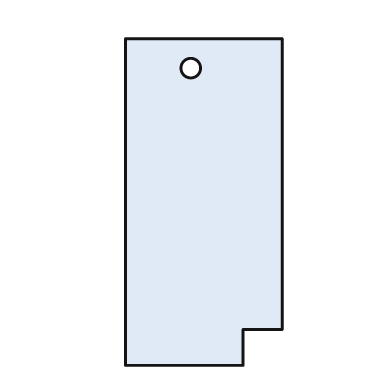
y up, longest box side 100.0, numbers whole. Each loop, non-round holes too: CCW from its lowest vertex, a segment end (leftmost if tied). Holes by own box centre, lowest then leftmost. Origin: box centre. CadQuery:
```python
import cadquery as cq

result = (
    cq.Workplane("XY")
    .moveTo(-24.0, -50.0)
    .lineTo(12.0, -50.0)
    .lineTo(12.0, -39.0)
    .lineTo(24.0, -39.0)
    .lineTo(24.0, 50.0)
    .lineTo(-24.0, 50.0)
    .close()
    .moveTo(-4.0, 41.0)
    .circle(3.0)
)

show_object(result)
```